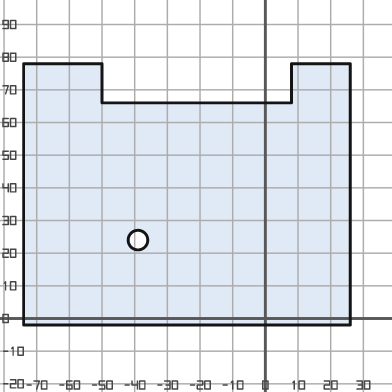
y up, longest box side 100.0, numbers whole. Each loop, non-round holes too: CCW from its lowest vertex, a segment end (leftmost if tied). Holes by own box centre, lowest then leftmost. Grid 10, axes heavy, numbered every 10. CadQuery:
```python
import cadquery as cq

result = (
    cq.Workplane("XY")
    .moveTo(-74.0, -2.0)
    .lineTo(26.0, -2.0)
    .lineTo(26.0, 78.0)
    .lineTo(8.0, 78.0)
    .lineTo(8.0, 66.0)
    .lineTo(-50.0, 66.0)
    .lineTo(-50.0, 78.0)
    .lineTo(-74.0, 78.0)
    .close()
    .moveTo(-39.0, 24.0)
    .circle(3.0)
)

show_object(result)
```